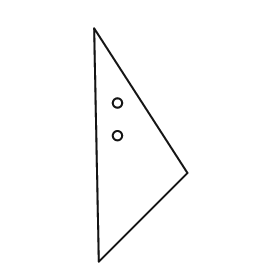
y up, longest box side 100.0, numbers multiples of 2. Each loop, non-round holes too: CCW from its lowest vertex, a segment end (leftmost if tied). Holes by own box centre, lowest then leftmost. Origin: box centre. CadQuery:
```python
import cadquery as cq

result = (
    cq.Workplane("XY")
    .moveTo(-18.0, -50.0)
    .lineTo(20.0, -12.0)
    .lineTo(-20.0, 50.0)
    .close()
    .moveTo(-10.0, 4.0)
    .circle(2.0)
    .moveTo(-10.0, 18.0)
    .circle(2.0)
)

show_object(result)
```